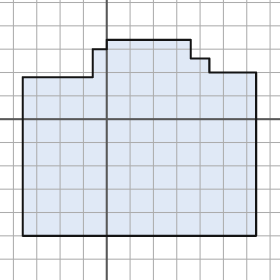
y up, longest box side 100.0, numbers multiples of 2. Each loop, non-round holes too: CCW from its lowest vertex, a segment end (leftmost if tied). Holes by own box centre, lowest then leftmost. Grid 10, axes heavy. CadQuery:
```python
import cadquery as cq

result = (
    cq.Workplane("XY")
    .moveTo(-36.0, -50.0)
    .lineTo(64.0, -50.0)
    .lineTo(64.0, 20.0)
    .lineTo(44.0, 20.0)
    .lineTo(44.0, 26.0)
    .lineTo(36.0, 26.0)
    .lineTo(36.0, 34.0)
    .lineTo(0.0, 34.0)
    .lineTo(0.0, 30.0)
    .lineTo(-6.0, 30.0)
    .lineTo(-6.0, 18.0)
    .lineTo(-36.0, 18.0)
    .close()
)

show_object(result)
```